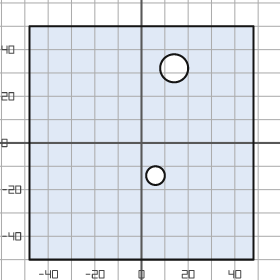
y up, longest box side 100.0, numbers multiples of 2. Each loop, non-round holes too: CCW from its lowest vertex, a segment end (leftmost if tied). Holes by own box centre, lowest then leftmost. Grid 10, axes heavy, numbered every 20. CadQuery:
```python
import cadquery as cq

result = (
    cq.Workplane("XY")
    .moveTo(-48.0, -50.0)
    .lineTo(48.0, -50.0)
    .lineTo(48.0, 50.0)
    .lineTo(-48.0, 50.0)
    .close()
    .moveTo(6.0, -14.0)
    .circle(4.0)
    .moveTo(14.0, 32.0)
    .circle(6.0)
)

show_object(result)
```